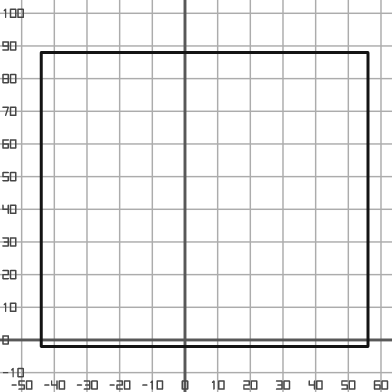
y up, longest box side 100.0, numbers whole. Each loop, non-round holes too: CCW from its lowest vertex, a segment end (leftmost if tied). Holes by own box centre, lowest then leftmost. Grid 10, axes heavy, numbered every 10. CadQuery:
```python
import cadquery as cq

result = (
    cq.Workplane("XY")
    .moveTo(-44.0, -2.0)
    .lineTo(56.0, -2.0)
    .lineTo(56.0, 88.0)
    .lineTo(-44.0, 88.0)
    .close()
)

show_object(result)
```